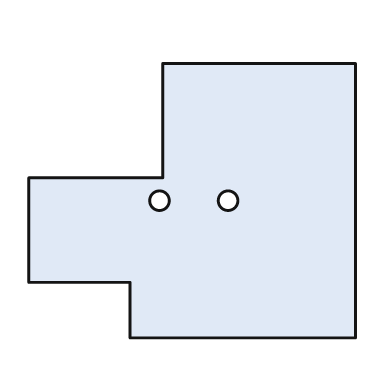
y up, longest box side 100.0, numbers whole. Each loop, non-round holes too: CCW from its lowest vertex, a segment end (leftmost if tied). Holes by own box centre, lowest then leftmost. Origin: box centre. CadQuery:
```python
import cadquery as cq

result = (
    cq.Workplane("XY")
    .moveTo(-19.0, -42.0)
    .lineTo(50.0, -42.0)
    .lineTo(50.0, 42.0)
    .lineTo(-9.0, 42.0)
    .lineTo(-9.0, 7.0)
    .lineTo(-50.0, 7.0)
    .lineTo(-50.0, -25.0)
    .lineTo(-19.0, -25.0)
    .close()
    .moveTo(-10.0, 0.0)
    .circle(3.0)
    .moveTo(11.0, 0.0)
    .circle(3.0)
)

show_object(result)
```